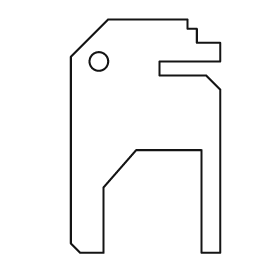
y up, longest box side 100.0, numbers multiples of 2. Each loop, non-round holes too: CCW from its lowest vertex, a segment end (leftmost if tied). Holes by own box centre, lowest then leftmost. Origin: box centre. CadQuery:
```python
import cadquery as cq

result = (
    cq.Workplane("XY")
    .moveTo(-28.0, -50.0)
    .lineTo(-18.0, -50.0)
    .lineTo(-18.0, -22.0)
    .lineTo(-4.0, -6.0)
    .lineTo(24.0, -6.0)
    .lineTo(24.0, -50.0)
    .lineTo(32.0, -50.0)
    .lineTo(32.0, 20.0)
    .lineTo(26.0, 26.0)
    .lineTo(6.0, 26.0)
    .lineTo(6.0, 32.0)
    .lineTo(32.0, 32.0)
    .lineTo(32.0, 40.0)
    .lineTo(22.0, 40.0)
    .lineTo(22.0, 46.0)
    .lineTo(18.0, 46.0)
    .lineTo(18.0, 50.0)
    .lineTo(-16.0, 50.0)
    .lineTo(-32.0, 34.0)
    .lineTo(-32.0, -46.0)
    .close()
    .moveTo(-20.0, 32.0)
    .circle(4.0)
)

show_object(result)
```